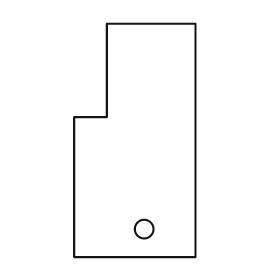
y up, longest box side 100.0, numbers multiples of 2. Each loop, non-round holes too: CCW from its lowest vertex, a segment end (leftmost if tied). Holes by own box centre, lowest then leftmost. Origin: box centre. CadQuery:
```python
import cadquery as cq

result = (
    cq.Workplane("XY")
    .moveTo(-26.0, -50.0)
    .lineTo(26.0, -50.0)
    .lineTo(26.0, 50.0)
    .lineTo(-12.0, 50.0)
    .lineTo(-12.0, 10.0)
    .lineTo(-26.0, 10.0)
    .close()
    .moveTo(4.0, -38.0)
    .circle(4.0)
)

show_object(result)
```